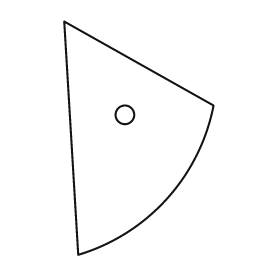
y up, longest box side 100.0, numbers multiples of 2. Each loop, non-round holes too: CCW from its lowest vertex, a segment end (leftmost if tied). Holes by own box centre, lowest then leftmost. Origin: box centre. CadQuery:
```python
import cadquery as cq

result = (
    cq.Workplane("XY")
    .moveTo(-26.0, -50.0)
    .threePointArc((12.0, -26.0), (32.0, 14.0))
    .lineTo(-32.0, 50.0)
    .close()
    .moveTo(-6.0, 10.0)
    .circle(4.0)
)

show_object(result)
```